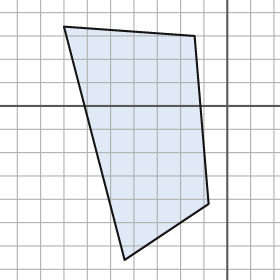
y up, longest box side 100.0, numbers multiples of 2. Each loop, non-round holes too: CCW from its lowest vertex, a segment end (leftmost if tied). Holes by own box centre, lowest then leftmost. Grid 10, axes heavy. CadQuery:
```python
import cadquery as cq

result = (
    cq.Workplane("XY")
    .moveTo(-44.0, -66.0)
    .lineTo(-8.0, -42.0)
    .lineTo(-14.0, 30.0)
    .lineTo(-70.0, 34.0)
    .close()
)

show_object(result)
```